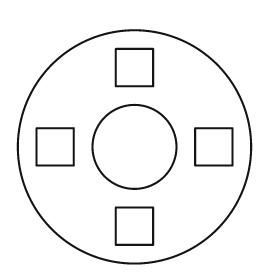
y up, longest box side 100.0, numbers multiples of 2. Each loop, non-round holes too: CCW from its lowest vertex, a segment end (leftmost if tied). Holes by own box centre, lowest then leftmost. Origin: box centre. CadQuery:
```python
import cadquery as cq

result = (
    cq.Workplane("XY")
    .moveTo(0.0, 0.0)
    .circle(50.0)
    .moveTo(-8.0, -42.0)
    .lineTo(8.0, -42.0)
    .lineTo(8.0, -26.0)
    .lineTo(-8.0, -26.0)
    .close()
    .moveTo(-42.0, -8.0)
    .lineTo(-26.0, -8.0)
    .lineTo(-26.0, 8.0)
    .lineTo(-42.0, 8.0)
    .close()
    .moveTo(0.0, 0.0)
    .circle(18.0)
    .moveTo(26.0, -8.0)
    .lineTo(42.0, -8.0)
    .lineTo(42.0, 8.0)
    .lineTo(26.0, 8.0)
    .close()
    .moveTo(-8.0, 26.0)
    .lineTo(8.0, 26.0)
    .lineTo(8.0, 42.0)
    .lineTo(-8.0, 42.0)
    .close()
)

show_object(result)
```